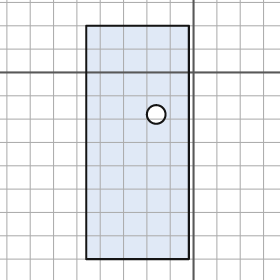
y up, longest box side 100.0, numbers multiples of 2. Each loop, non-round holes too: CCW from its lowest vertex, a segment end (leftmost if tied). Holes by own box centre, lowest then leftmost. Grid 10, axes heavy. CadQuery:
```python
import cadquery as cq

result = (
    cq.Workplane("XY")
    .moveTo(-46.0, -80.0)
    .lineTo(-2.0, -80.0)
    .lineTo(-2.0, 20.0)
    .lineTo(-46.0, 20.0)
    .close()
    .moveTo(-16.0, -18.0)
    .circle(4.0)
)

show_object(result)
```